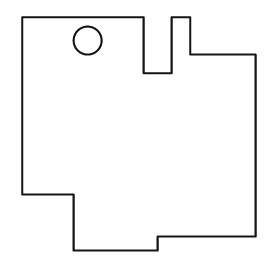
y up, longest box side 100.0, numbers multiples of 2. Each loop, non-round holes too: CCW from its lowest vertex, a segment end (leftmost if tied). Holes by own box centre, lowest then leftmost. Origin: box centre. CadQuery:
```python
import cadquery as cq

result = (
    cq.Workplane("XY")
    .moveTo(-28.0, -50.0)
    .lineTo(8.0, -50.0)
    .lineTo(8.0, -44.0)
    .lineTo(50.0, -44.0)
    .lineTo(50.0, 34.0)
    .lineTo(22.0, 34.0)
    .lineTo(22.0, 50.0)
    .lineTo(14.0, 50.0)
    .lineTo(14.0, 26.0)
    .lineTo(2.0, 26.0)
    .lineTo(2.0, 50.0)
    .lineTo(-50.0, 50.0)
    .lineTo(-50.0, -26.0)
    .lineTo(-28.0, -26.0)
    .close()
    .moveTo(-22.0, 40.0)
    .circle(6.0)
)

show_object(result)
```